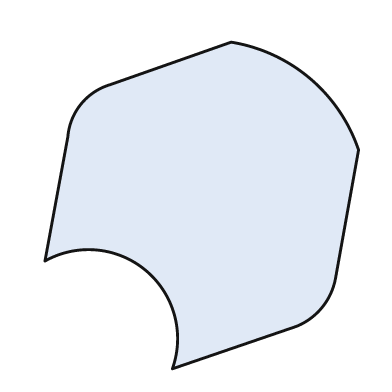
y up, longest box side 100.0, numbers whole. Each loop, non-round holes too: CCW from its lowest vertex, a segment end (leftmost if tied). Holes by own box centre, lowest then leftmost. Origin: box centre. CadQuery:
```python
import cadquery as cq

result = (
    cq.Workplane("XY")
    .moveTo(-9.0, -50.0)
    .lineTo(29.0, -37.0)
    .threePointArc((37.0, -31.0), (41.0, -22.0))
    .lineTo(48.0, 17.0)
    .threePointArc((33.0, 39.0), (9.0, 50.0))
    .lineTo(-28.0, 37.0)
    .threePointArc((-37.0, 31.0), (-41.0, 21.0))
    .lineTo(-48.0, -17.0)
    .threePointArc((-17.0, -20.0), (-9.0, -50.0))
    .close()
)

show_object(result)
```